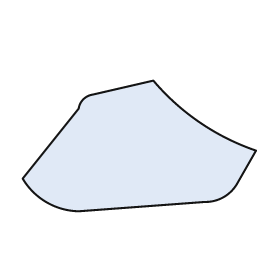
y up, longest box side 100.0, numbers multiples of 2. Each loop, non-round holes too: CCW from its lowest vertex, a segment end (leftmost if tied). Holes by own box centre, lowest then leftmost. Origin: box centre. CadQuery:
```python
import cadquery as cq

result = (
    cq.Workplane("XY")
    .moveTo(-26.0, -28.0)
    .lineTo(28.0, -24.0)
    .threePointArc((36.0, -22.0), (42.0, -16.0))
    .lineTo(50.0, -2.0)
    .threePointArc((26.0, 10.0), (6.0, 28.0))
    .lineTo(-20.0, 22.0)
    .threePointArc((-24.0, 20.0), (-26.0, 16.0))
    .lineTo(-50.0, -14.0)
    .threePointArc((-40.0, -24.0), (-26.0, -28.0))
    .close()
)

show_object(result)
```